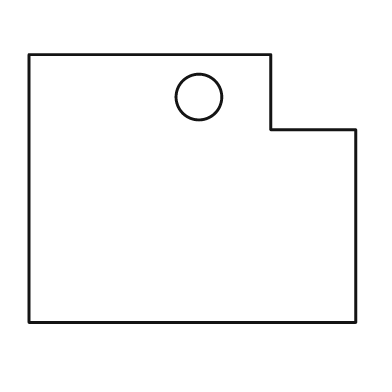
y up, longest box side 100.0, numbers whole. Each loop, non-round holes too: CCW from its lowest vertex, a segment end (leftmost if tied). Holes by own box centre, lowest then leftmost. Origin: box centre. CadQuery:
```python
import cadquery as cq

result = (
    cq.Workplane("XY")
    .moveTo(-50.0, -41.0)
    .lineTo(50.0, -41.0)
    .lineTo(50.0, 18.0)
    .lineTo(24.0, 18.0)
    .lineTo(24.0, 41.0)
    .lineTo(-50.0, 41.0)
    .close()
    .moveTo(2.0, 28.0)
    .circle(7.0)
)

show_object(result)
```